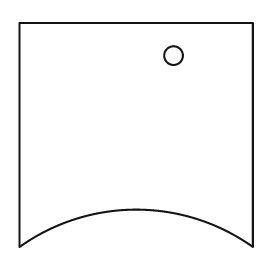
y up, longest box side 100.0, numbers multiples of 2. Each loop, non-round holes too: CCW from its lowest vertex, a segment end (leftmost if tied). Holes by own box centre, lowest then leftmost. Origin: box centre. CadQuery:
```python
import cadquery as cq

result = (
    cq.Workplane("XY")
    .moveTo(-50.0, -48.0)
    .threePointArc((0.0, -32.0), (50.0, -48.0))
    .lineTo(50.0, 48.0)
    .lineTo(-50.0, 48.0)
    .close()
    .moveTo(16.0, 34.0)
    .circle(4.0)
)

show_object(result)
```